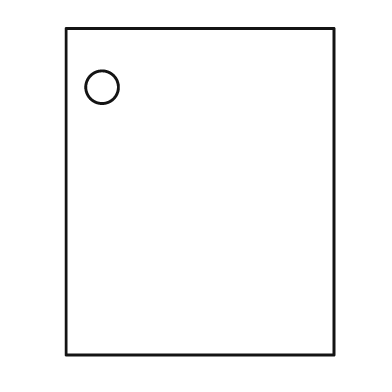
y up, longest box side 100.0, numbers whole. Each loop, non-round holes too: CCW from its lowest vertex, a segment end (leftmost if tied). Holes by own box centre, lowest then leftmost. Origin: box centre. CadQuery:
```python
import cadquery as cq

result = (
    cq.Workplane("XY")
    .moveTo(-41.0, -50.0)
    .lineTo(41.0, -50.0)
    .lineTo(41.0, 50.0)
    .lineTo(-41.0, 50.0)
    .close()
    .moveTo(-30.0, 32.0)
    .circle(5.0)
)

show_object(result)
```